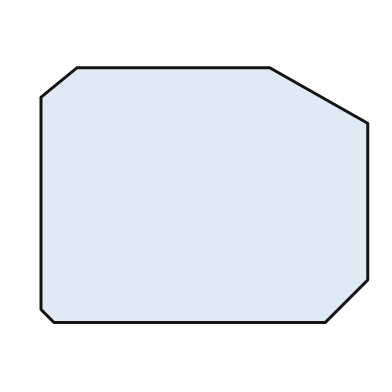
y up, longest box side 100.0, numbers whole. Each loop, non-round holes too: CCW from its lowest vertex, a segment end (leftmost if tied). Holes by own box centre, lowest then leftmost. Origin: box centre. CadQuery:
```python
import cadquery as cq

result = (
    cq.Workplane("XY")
    .moveTo(-46.0, -39.0)
    .lineTo(37.0, -39.0)
    .lineTo(50.0, -26.0)
    .lineTo(50.0, 22.0)
    .lineTo(20.0, 39.0)
    .lineTo(-39.0, 39.0)
    .lineTo(-50.0, 30.0)
    .lineTo(-50.0, -35.0)
    .close()
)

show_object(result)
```